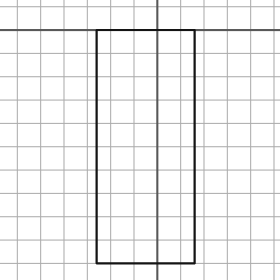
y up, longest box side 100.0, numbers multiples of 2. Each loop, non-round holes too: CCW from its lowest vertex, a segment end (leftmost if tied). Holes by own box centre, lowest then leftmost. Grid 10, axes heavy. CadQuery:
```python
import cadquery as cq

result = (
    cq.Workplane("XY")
    .moveTo(-26.0, -100.0)
    .lineTo(16.0, -100.0)
    .lineTo(16.0, 0.0)
    .lineTo(-26.0, 0.0)
    .close()
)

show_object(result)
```